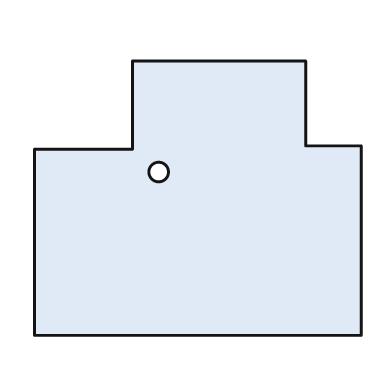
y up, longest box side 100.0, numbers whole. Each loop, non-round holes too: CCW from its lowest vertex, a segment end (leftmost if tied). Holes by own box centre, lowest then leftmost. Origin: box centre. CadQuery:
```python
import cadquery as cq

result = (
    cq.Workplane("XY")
    .moveTo(-50.0, -42.0)
    .lineTo(50.0, -42.0)
    .lineTo(50.0, 16.0)
    .lineTo(33.0, 16.0)
    .lineTo(33.0, 42.0)
    .lineTo(-20.0, 42.0)
    .lineTo(-20.0, 15.0)
    .lineTo(-50.0, 15.0)
    .close()
    .moveTo(-12.0, 8.0)
    .circle(3.0)
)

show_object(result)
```